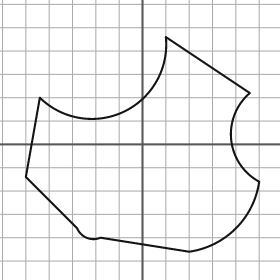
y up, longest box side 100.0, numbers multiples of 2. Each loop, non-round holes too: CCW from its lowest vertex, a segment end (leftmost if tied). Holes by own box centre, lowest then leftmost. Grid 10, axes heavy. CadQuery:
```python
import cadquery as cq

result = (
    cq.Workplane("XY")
    .moveTo(20.0, -46.0)
    .threePointArc((40.0, -36.0), (50.0, -16.0))
    .threePointArc((38.0, 2.0), (46.0, 22.0))
    .lineTo(10.0, 46.0)
    .threePointArc((-8.0, 14.0), (-44.0, 20.0))
    .lineTo(-50.0, -14.0)
    .lineTo(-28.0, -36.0)
    .threePointArc((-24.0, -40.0), (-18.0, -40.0))
    .close()
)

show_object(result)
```